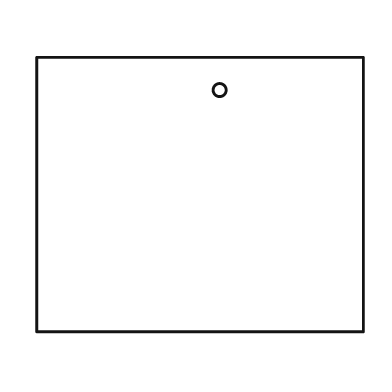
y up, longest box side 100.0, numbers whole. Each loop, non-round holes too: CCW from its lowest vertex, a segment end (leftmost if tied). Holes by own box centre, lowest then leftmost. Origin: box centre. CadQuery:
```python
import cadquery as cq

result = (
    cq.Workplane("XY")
    .moveTo(-50.0, -42.0)
    .lineTo(50.0, -42.0)
    .lineTo(50.0, 42.0)
    .lineTo(-50.0, 42.0)
    .close()
    .moveTo(6.0, 32.0)
    .circle(2.0)
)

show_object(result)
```